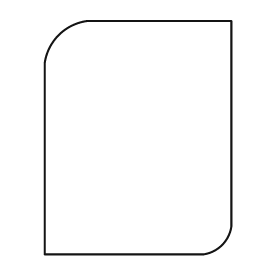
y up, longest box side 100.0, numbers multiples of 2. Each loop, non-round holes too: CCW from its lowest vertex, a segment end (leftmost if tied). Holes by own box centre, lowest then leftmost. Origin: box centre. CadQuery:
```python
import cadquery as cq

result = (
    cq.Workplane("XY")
    .moveTo(-40.0, -50.0)
    .lineTo(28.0, -50.0)
    .threePointArc((36.0, -46.0), (40.0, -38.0))
    .lineTo(40.0, 50.0)
    .lineTo(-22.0, 50.0)
    .threePointArc((-34.0, 44.0), (-40.0, 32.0))
    .close()
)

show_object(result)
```